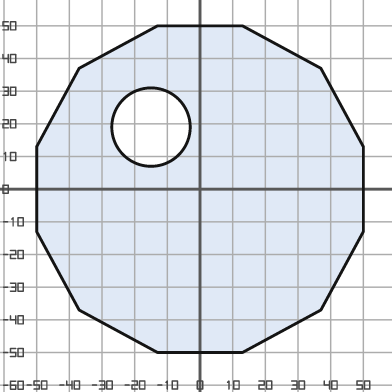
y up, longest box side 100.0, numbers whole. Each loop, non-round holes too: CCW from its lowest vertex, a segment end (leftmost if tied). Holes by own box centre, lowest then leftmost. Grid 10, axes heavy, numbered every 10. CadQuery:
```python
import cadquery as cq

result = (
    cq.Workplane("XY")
    .moveTo(-13.0, -50.0)
    .lineTo(13.0, -50.0)
    .lineTo(37.0, -37.0)
    .lineTo(50.0, -13.0)
    .lineTo(50.0, 13.0)
    .lineTo(37.0, 37.0)
    .lineTo(13.0, 50.0)
    .lineTo(-13.0, 50.0)
    .lineTo(-37.0, 37.0)
    .lineTo(-50.0, 13.0)
    .lineTo(-50.0, -13.0)
    .lineTo(-37.0, -37.0)
    .close()
    .moveTo(-15.0, 19.0)
    .circle(12.0)
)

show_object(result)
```